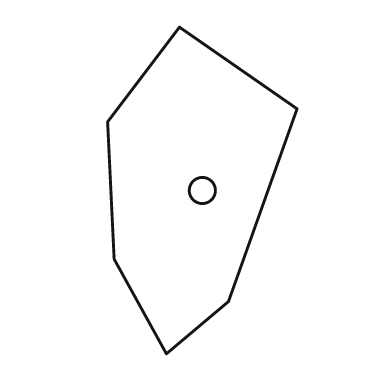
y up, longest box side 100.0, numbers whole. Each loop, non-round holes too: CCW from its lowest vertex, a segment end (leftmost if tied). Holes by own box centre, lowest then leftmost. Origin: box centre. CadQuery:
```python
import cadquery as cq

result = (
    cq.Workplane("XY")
    .moveTo(-11.0, -50.0)
    .lineTo(8.0, -34.0)
    .lineTo(29.0, 25.0)
    .lineTo(-7.0, 50.0)
    .lineTo(-29.0, 21.0)
    .lineTo(-27.0, -21.0)
    .close()
    .moveTo(0.0, 0.0)
    .circle(4.0)
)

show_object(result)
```